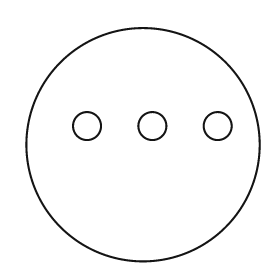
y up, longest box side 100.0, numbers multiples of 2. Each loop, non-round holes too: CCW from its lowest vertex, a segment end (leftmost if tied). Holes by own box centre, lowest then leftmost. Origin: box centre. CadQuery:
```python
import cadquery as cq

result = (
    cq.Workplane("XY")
    .moveTo(0.0, 0.0)
    .circle(50.0)
    .moveTo(-24.0, 8.0)
    .circle(6.0)
    .moveTo(4.0, 8.0)
    .circle(6.0)
    .moveTo(32.0, 8.0)
    .circle(6.0)
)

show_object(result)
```